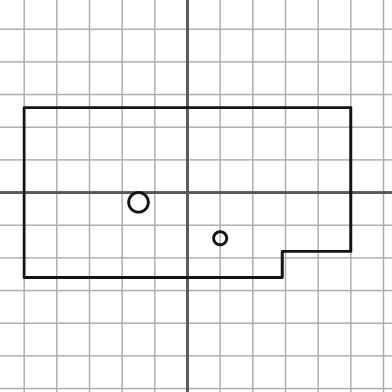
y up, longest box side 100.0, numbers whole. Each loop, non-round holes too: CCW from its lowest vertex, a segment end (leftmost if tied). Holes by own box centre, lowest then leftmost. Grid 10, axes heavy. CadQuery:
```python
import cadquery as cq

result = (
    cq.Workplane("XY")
    .moveTo(-50.0, -26.0)
    .lineTo(29.0, -26.0)
    .lineTo(29.0, -18.0)
    .lineTo(50.0, -18.0)
    .lineTo(50.0, 26.0)
    .lineTo(-50.0, 26.0)
    .close()
    .moveTo(10.0, -14.0)
    .circle(2.0)
    .moveTo(-15.0, -3.0)
    .circle(3.0)
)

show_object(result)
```